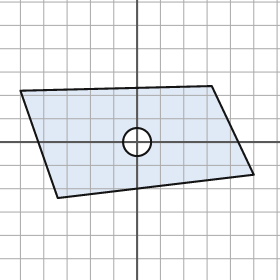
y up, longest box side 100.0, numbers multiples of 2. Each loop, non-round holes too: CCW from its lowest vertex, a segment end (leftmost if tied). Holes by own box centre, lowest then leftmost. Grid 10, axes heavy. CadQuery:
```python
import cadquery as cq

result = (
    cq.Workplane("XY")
    .moveTo(-34.0, -24.0)
    .lineTo(50.0, -14.0)
    .lineTo(32.0, 24.0)
    .lineTo(-50.0, 22.0)
    .close()
    .moveTo(0.0, 0.0)
    .circle(6.0)
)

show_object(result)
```